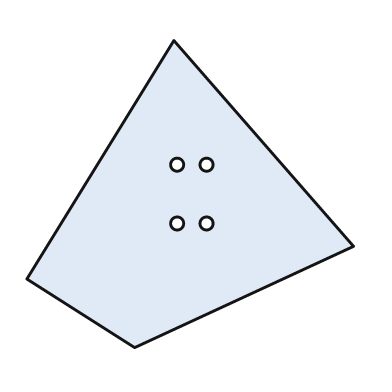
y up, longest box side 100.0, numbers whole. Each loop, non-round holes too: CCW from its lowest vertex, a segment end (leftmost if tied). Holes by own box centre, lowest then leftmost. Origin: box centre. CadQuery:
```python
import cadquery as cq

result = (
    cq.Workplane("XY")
    .moveTo(-17.0, -47.0)
    .lineTo(50.0, -16.0)
    .lineTo(-5.0, 47.0)
    .lineTo(-50.0, -26.0)
    .close()
    .moveTo(-4.0, -9.0)
    .circle(2.0)
    .moveTo(5.0, -9.0)
    .circle(2.0)
    .moveTo(-4.0, 9.0)
    .circle(2.0)
    .moveTo(5.0, 9.0)
    .circle(2.0)
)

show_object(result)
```